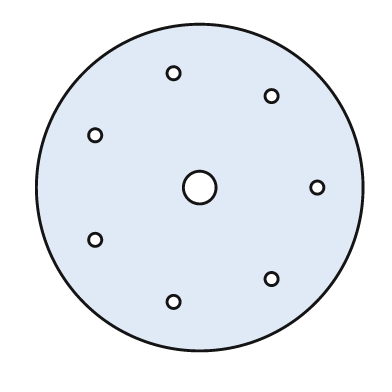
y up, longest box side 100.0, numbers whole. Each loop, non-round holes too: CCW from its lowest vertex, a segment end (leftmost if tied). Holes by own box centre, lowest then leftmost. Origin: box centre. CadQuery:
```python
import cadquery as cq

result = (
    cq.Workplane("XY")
    .moveTo(0.0, 0.0)
    .circle(50.0)
    .moveTo(-8.0, -35.0)
    .circle(2.0)
    .moveTo(22.0, -28.0)
    .circle(2.0)
    .moveTo(-32.0, -16.0)
    .circle(2.0)
    .moveTo(0.0, 0.0)
    .circle(5.0)
    .moveTo(36.0, 0.0)
    .circle(2.0)
    .moveTo(-32.0, 16.0)
    .circle(2.0)
    .moveTo(22.0, 28.0)
    .circle(2.0)
    .moveTo(-8.0, 35.0)
    .circle(2.0)
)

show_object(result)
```